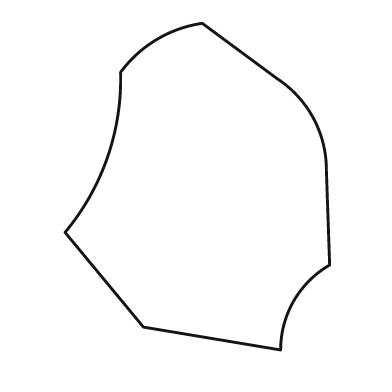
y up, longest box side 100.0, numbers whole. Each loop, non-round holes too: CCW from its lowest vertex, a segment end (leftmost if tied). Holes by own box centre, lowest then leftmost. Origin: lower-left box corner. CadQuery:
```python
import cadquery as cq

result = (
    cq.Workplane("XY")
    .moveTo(66.0, 0.0)
    .threePointArc((70.0, 15.0), (81.0, 26.0))
    .lineTo(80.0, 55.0)
    .threePointArc((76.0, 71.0), (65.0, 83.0))
    .lineTo(42.0, 100.0)
    .threePointArc((28.0, 95.0), (17.0, 85.0))
    .threePointArc((13.0, 59.0), (0.0, 36.0))
    .lineTo(24.0, 7.0)
    .close()
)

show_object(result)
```